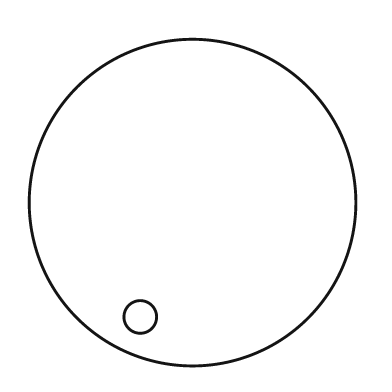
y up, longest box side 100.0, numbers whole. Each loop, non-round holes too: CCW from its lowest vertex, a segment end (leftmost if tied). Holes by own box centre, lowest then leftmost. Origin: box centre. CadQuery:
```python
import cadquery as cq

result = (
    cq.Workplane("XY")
    .moveTo(0.0, 0.0)
    .circle(50.0)
    .moveTo(-16.0, -35.0)
    .circle(5.0)
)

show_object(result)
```